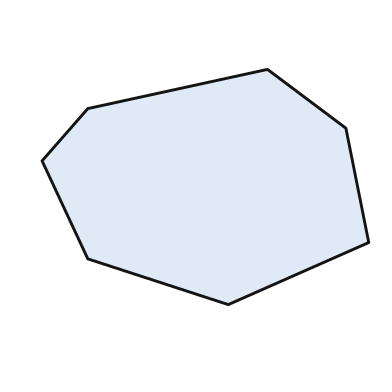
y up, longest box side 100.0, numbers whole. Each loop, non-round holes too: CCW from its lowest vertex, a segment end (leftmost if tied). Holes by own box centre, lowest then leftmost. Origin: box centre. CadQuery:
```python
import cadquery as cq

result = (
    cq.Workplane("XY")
    .moveTo(7.0, -36.0)
    .lineTo(50.0, -17.0)
    .lineTo(43.0, 18.0)
    .lineTo(19.0, 36.0)
    .lineTo(-36.0, 24.0)
    .lineTo(-50.0, 8.0)
    .lineTo(-36.0, -22.0)
    .close()
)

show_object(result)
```